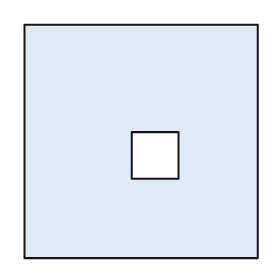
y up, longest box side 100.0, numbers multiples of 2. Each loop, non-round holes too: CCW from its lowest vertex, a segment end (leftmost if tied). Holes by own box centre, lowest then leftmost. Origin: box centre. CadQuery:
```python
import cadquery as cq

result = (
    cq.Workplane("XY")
    .moveTo(-50.0, -50.0)
    .lineTo(50.0, -50.0)
    .lineTo(50.0, 50.0)
    .lineTo(-50.0, 50.0)
    .close()
    .moveTo(-4.0, -16.0)
    .lineTo(16.0, -16.0)
    .lineTo(16.0, 4.0)
    .lineTo(-4.0, 4.0)
    .close()
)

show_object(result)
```